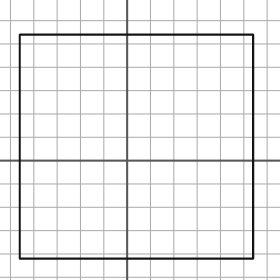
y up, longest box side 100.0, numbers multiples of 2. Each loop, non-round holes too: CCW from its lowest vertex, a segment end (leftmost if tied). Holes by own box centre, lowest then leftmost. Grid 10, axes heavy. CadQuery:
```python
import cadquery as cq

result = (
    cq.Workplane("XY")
    .moveTo(-46.0, -42.0)
    .lineTo(54.0, -42.0)
    .lineTo(54.0, 54.0)
    .lineTo(-46.0, 54.0)
    .close()
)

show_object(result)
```